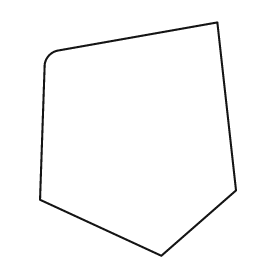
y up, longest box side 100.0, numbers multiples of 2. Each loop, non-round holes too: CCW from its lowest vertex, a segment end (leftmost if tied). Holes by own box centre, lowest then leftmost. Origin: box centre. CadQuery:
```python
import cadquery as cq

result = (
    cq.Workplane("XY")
    .moveTo(10.0, -50.0)
    .lineTo(42.0, -22.0)
    .lineTo(34.0, 50.0)
    .lineTo(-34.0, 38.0)
    .threePointArc((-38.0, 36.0), (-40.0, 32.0))
    .lineTo(-42.0, -26.0)
    .close()
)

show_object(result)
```